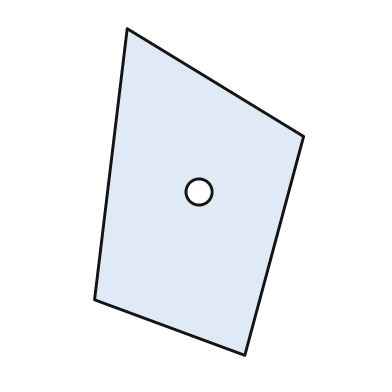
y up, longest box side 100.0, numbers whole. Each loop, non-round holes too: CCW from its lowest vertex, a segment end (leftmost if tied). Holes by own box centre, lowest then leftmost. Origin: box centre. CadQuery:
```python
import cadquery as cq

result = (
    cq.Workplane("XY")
    .moveTo(14.0, -50.0)
    .lineTo(32.0, 17.0)
    .lineTo(-22.0, 50.0)
    .lineTo(-32.0, -33.0)
    .close()
    .moveTo(0.0, 0.0)
    .circle(4.0)
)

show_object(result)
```